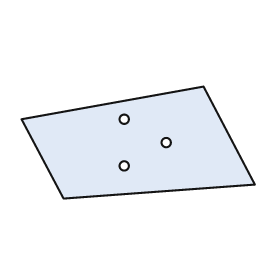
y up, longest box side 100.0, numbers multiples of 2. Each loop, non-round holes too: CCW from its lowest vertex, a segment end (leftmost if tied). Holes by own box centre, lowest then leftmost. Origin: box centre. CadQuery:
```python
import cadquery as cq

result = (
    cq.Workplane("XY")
    .moveTo(-32.0, -24.0)
    .lineTo(50.0, -18.0)
    .lineTo(28.0, 24.0)
    .lineTo(-50.0, 10.0)
    .close()
    .moveTo(-6.0, -10.0)
    .circle(2.0)
    .moveTo(12.0, 0.0)
    .circle(2.0)
    .moveTo(-6.0, 10.0)
    .circle(2.0)
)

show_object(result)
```